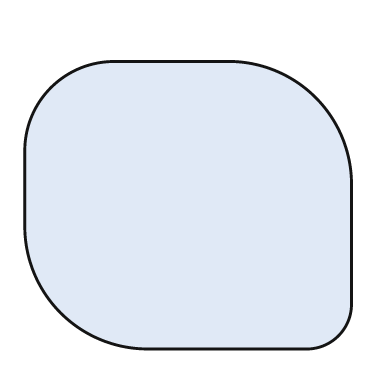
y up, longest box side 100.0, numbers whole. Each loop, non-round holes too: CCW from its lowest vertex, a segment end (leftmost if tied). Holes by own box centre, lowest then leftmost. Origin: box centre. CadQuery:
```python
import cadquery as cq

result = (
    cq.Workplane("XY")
    .moveTo(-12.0, -44.0)
    .lineTo(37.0, -44.0)
    .threePointArc((46.0, -40.0), (50.0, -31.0))
    .lineTo(50.0, 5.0)
    .threePointArc((39.0, 33.0), (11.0, 44.0))
    .lineTo(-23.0, 44.0)
    .threePointArc((-42.0, 36.0), (-50.0, 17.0))
    .lineTo(-50.0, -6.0)
    .threePointArc((-39.0, -33.0), (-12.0, -44.0))
    .close()
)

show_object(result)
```